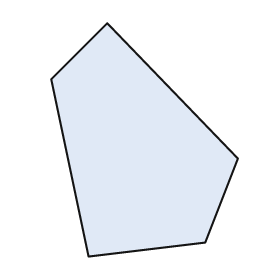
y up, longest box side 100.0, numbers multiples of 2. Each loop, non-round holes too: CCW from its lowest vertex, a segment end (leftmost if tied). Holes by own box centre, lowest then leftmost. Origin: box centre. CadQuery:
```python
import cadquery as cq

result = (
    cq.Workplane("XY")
    .moveTo(-24.0, -50.0)
    .lineTo(26.0, -44.0)
    .lineTo(40.0, -8.0)
    .lineTo(-16.0, 50.0)
    .lineTo(-40.0, 26.0)
    .close()
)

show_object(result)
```